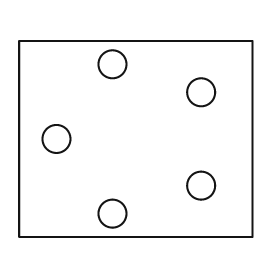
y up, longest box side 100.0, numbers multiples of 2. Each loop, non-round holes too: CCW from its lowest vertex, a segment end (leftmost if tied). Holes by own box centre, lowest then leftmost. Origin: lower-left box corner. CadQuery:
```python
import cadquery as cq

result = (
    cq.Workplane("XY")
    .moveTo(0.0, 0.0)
    .lineTo(100.0, 0.0)
    .lineTo(100.0, 84.0)
    .lineTo(0.0, 84.0)
    .close()
    .moveTo(40.0, 10.0)
    .circle(6.0)
    .moveTo(78.0, 22.0)
    .circle(6.0)
    .moveTo(16.0, 42.0)
    .circle(6.0)
    .moveTo(78.0, 62.0)
    .circle(6.0)
    .moveTo(40.0, 74.0)
    .circle(6.0)
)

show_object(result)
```